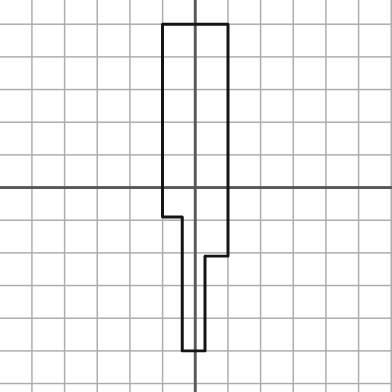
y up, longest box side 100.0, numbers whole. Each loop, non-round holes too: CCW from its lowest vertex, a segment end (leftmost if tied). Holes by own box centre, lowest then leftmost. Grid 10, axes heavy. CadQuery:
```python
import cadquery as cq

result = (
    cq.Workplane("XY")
    .moveTo(-4.0, -50.0)
    .lineTo(3.0, -50.0)
    .lineTo(3.0, -21.0)
    .lineTo(10.0, -21.0)
    .lineTo(10.0, 50.0)
    .lineTo(-10.0, 50.0)
    .lineTo(-10.0, -9.0)
    .lineTo(-4.0, -9.0)
    .close()
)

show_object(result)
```